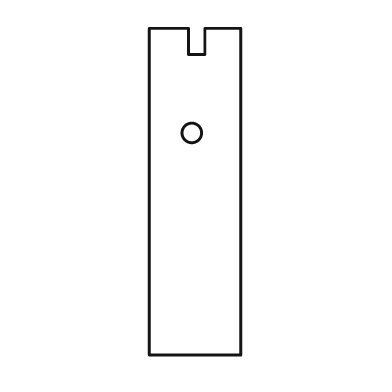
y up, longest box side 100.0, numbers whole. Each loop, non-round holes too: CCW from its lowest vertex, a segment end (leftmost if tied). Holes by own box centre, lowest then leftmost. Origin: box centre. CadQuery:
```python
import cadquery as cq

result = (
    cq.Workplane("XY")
    .moveTo(-14.0, -50.0)
    .lineTo(14.0, -50.0)
    .lineTo(14.0, 50.0)
    .lineTo(3.0, 50.0)
    .lineTo(3.0, 42.0)
    .lineTo(-2.0, 42.0)
    .lineTo(-2.0, 50.0)
    .lineTo(-14.0, 50.0)
    .close()
    .moveTo(-1.0, 18.0)
    .circle(3.0)
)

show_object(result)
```